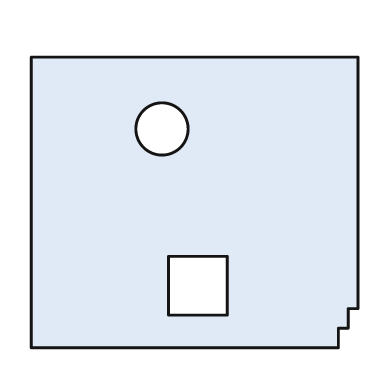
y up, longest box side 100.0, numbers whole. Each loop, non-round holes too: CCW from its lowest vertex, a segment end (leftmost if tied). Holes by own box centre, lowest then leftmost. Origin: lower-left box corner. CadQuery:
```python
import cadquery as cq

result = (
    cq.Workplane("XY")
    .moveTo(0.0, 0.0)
    .lineTo(94.0, 0.0)
    .lineTo(94.0, 6.0)
    .lineTo(97.0, 6.0)
    .lineTo(97.0, 12.0)
    .lineTo(100.0, 12.0)
    .lineTo(100.0, 89.0)
    .lineTo(0.0, 89.0)
    .close()
    .moveTo(42.0, 10.0)
    .lineTo(60.0, 10.0)
    .lineTo(60.0, 28.0)
    .lineTo(42.0, 28.0)
    .close()
    .moveTo(40.0, 67.0)
    .circle(8.0)
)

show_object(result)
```